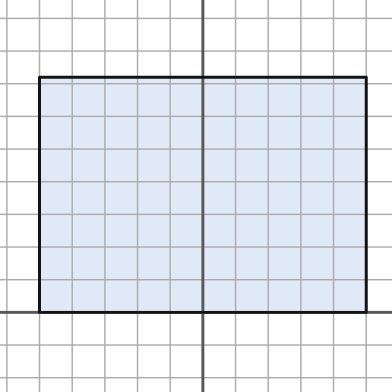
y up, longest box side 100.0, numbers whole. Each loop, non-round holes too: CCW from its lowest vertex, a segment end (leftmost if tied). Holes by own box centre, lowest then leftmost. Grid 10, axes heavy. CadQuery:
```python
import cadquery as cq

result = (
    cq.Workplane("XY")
    .moveTo(-50.0, 0.0)
    .lineTo(50.0, 0.0)
    .lineTo(50.0, 72.0)
    .lineTo(-50.0, 72.0)
    .close()
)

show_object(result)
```